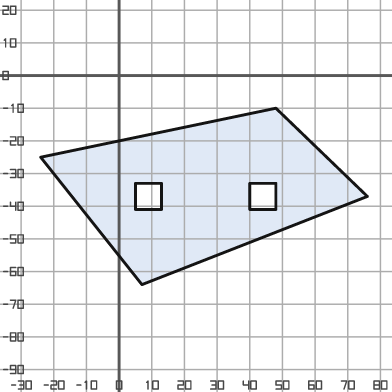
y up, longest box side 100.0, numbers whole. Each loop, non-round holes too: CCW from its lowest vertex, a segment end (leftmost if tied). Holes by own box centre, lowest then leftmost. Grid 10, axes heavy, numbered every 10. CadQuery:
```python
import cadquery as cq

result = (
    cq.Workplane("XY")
    .moveTo(7.0, -64.0)
    .lineTo(76.0, -37.0)
    .lineTo(48.0, -10.0)
    .lineTo(-24.0, -25.0)
    .close()
    .moveTo(5.0, -41.0)
    .lineTo(13.0, -41.0)
    .lineTo(13.0, -33.0)
    .lineTo(5.0, -33.0)
    .close()
    .moveTo(40.0, -41.0)
    .lineTo(48.0, -41.0)
    .lineTo(48.0, -33.0)
    .lineTo(40.0, -33.0)
    .close()
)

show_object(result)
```